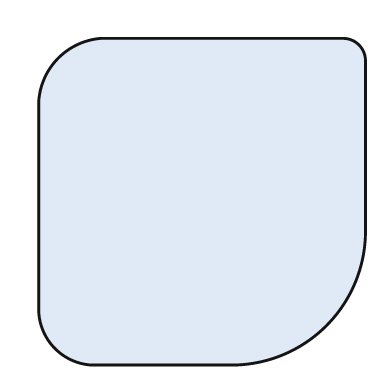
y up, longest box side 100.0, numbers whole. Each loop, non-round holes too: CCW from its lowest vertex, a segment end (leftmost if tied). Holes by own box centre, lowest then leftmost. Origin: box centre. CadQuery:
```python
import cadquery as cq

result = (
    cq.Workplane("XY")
    .moveTo(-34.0, -50.0)
    .lineTo(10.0, -50.0)
    .threePointArc((38.0, -38.0), (50.0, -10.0))
    .lineTo(50.0, 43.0)
    .threePointArc((48.0, 48.0), (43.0, 50.0))
    .lineTo(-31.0, 50.0)
    .threePointArc((-44.0, 44.0), (-50.0, 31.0))
    .lineTo(-50.0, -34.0)
    .threePointArc((-45.0, -45.0), (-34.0, -50.0))
    .close()
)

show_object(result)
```